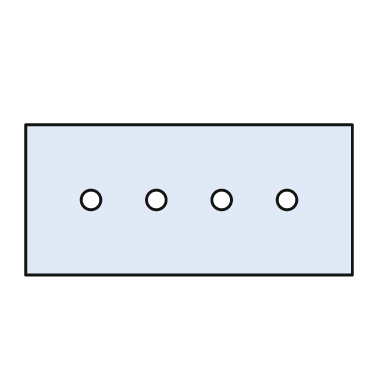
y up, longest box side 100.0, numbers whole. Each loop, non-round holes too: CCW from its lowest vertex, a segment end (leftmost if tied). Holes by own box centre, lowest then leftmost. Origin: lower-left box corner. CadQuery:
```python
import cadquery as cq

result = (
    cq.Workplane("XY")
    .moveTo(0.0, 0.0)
    .lineTo(100.0, 0.0)
    .lineTo(100.0, 46.0)
    .lineTo(0.0, 46.0)
    .close()
    .moveTo(20.0, 23.0)
    .circle(3.0)
    .moveTo(40.0, 23.0)
    .circle(3.0)
    .moveTo(60.0, 23.0)
    .circle(3.0)
    .moveTo(80.0, 23.0)
    .circle(3.0)
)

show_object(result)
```